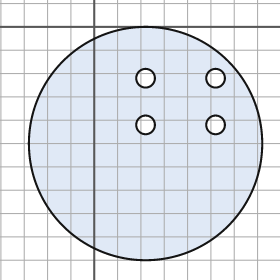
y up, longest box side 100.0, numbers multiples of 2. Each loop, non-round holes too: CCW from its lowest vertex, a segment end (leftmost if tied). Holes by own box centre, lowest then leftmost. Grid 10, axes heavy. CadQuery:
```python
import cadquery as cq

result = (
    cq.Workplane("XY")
    .moveTo(22.0, -50.0)
    .circle(50.0)
    .moveTo(22.0, -42.0)
    .circle(4.0)
    .moveTo(52.0, -42.0)
    .circle(4.0)
    .moveTo(22.0, -22.0)
    .circle(4.0)
    .moveTo(52.0, -22.0)
    .circle(4.0)
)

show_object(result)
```